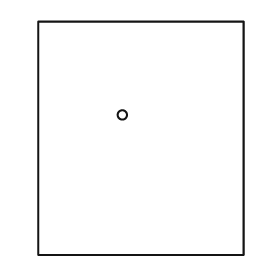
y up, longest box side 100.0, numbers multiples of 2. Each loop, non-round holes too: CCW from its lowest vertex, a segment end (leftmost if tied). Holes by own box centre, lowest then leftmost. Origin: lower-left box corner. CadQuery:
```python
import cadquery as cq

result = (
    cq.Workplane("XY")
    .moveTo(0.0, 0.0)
    .lineTo(88.0, 0.0)
    .lineTo(88.0, 100.0)
    .lineTo(0.0, 100.0)
    .close()
    .moveTo(36.0, 60.0)
    .circle(2.0)
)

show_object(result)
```